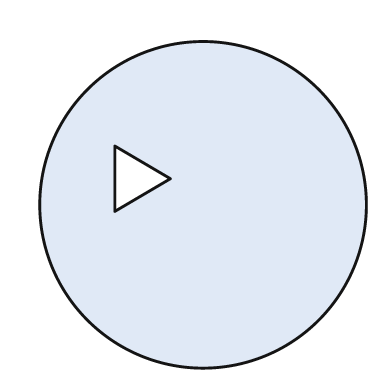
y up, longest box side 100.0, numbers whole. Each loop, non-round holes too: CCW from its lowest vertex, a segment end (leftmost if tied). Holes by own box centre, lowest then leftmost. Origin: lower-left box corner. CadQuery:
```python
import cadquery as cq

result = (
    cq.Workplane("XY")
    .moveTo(50.0, 50.0)
    .circle(50.0)
    .moveTo(23.0, 48.0)
    .lineTo(40.0, 58.0)
    .lineTo(23.0, 68.0)
    .close()
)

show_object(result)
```